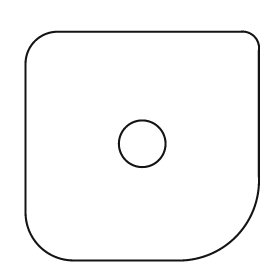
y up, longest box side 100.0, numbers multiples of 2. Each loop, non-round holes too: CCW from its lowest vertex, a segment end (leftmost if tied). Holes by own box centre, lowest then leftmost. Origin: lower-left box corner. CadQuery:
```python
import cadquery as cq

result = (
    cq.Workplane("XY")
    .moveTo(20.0, 0.0)
    .lineTo(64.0, 0.0)
    .threePointArc((90.0, 10.0), (100.0, 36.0))
    .lineTo(100.0, 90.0)
    .threePointArc((98.0, 96.0), (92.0, 98.0))
    .lineTo(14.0, 98.0)
    .threePointArc((4.0, 94.0), (0.0, 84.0))
    .lineTo(0.0, 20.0)
    .threePointArc((6.0, 6.0), (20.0, 0.0))
    .close()
    .moveTo(50.0, 50.0)
    .circle(10.0)
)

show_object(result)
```